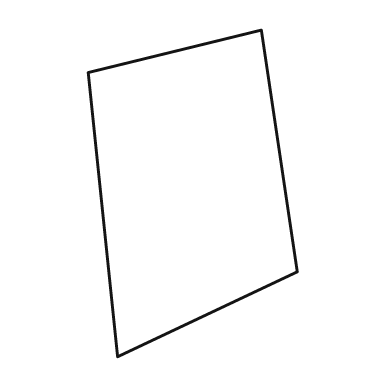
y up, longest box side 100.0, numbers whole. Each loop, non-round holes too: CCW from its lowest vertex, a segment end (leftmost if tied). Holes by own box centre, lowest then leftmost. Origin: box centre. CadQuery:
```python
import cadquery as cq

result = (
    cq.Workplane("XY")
    .moveTo(-23.0, -50.0)
    .lineTo(32.0, -24.0)
    .lineTo(21.0, 50.0)
    .lineTo(-32.0, 37.0)
    .close()
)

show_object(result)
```